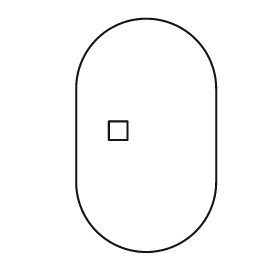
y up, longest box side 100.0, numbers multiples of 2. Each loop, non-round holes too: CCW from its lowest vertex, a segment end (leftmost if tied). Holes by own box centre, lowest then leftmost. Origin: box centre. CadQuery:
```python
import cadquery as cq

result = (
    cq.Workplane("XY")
    .moveTo(-30.0, -20.0)
    .threePointArc((0.0, -50.0), (30.0, -20.0))
    .lineTo(30.0, 20.0)
    .threePointArc((0.0, 50.0), (-30.0, 20.0))
    .close()
    .moveTo(-16.0, -2.0)
    .lineTo(-8.0, -2.0)
    .lineTo(-8.0, 6.0)
    .lineTo(-16.0, 6.0)
    .close()
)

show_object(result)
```